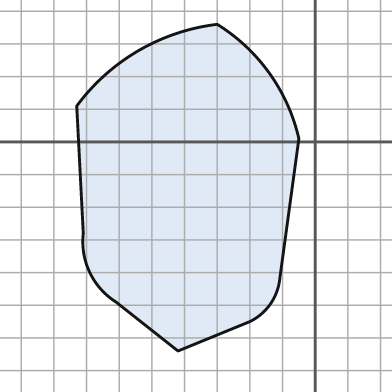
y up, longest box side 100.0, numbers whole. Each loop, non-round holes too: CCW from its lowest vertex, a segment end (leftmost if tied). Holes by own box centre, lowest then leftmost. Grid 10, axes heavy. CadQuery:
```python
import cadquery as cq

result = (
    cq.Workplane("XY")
    .moveTo(-42.0, -64.0)
    .lineTo(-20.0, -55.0)
    .threePointArc((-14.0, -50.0), (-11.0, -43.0))
    .lineTo(-5.0, 1.0)
    .threePointArc((-14.0, 21.0), (-30.0, 36.0))
    .threePointArc((-54.0, 28.0), (-73.0, 11.0))
    .lineTo(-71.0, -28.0)
    .threePointArc((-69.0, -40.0), (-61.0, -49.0))
    .close()
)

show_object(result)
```